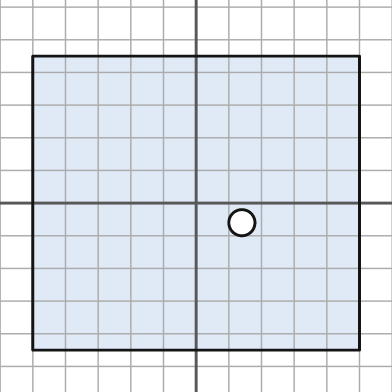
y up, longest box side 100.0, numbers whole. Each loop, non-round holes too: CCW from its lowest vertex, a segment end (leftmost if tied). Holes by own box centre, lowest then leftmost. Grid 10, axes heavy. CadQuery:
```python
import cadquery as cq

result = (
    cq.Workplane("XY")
    .moveTo(-50.0, -45.0)
    .lineTo(50.0, -45.0)
    .lineTo(50.0, 45.0)
    .lineTo(-50.0, 45.0)
    .close()
    .moveTo(14.0, -6.0)
    .circle(4.0)
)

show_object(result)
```